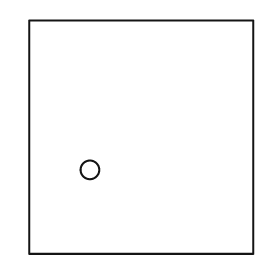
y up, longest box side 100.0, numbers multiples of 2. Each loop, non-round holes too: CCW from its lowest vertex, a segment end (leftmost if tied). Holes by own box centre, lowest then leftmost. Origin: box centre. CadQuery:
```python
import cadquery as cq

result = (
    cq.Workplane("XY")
    .moveTo(-48.0, -50.0)
    .lineTo(48.0, -50.0)
    .lineTo(48.0, 50.0)
    .lineTo(-48.0, 50.0)
    .close()
    .moveTo(-22.0, -14.0)
    .circle(4.0)
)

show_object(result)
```